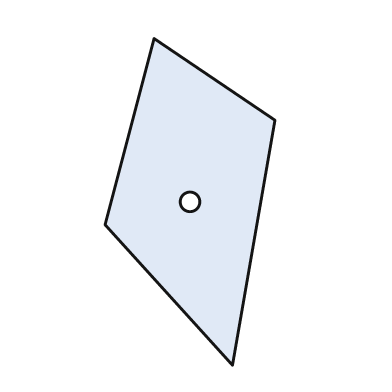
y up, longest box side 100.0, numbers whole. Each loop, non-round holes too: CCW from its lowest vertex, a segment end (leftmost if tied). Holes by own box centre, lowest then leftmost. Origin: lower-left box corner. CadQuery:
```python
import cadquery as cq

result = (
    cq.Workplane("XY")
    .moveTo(39.0, 0.0)
    .lineTo(52.0, 75.0)
    .lineTo(15.0, 100.0)
    .lineTo(0.0, 43.0)
    .close()
    .moveTo(26.0, 50.0)
    .circle(3.0)
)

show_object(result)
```